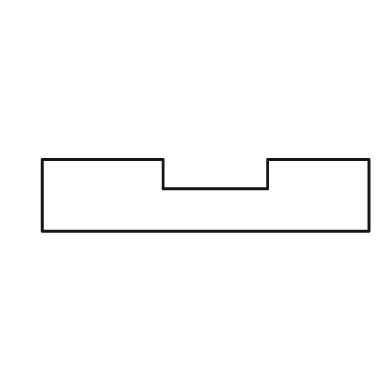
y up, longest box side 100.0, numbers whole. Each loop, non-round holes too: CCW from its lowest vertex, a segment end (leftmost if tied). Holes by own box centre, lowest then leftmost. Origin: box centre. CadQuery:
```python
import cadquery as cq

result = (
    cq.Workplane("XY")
    .moveTo(-50.0, -11.0)
    .lineTo(50.0, -11.0)
    .lineTo(50.0, 11.0)
    .lineTo(19.0, 11.0)
    .lineTo(19.0, 2.0)
    .lineTo(-13.0, 2.0)
    .lineTo(-13.0, 11.0)
    .lineTo(-50.0, 11.0)
    .close()
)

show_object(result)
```